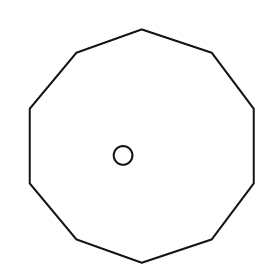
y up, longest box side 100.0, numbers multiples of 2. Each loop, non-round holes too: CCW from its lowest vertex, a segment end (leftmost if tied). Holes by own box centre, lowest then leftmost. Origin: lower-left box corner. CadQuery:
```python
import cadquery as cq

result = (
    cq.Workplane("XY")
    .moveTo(48.0, 0.0)
    .lineTo(78.0, 10.0)
    .lineTo(96.0, 34.0)
    .lineTo(96.0, 66.0)
    .lineTo(78.0, 90.0)
    .lineTo(48.0, 100.0)
    .lineTo(20.0, 90.0)
    .lineTo(0.0, 66.0)
    .lineTo(0.0, 34.0)
    .lineTo(20.0, 10.0)
    .close()
    .moveTo(40.0, 46.0)
    .circle(4.0)
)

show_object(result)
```